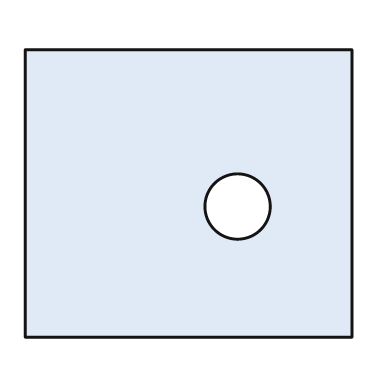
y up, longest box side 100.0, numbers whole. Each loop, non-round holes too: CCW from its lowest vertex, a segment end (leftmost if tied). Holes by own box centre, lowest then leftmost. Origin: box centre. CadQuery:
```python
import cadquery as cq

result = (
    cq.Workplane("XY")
    .moveTo(-50.0, -44.0)
    .lineTo(50.0, -44.0)
    .lineTo(50.0, 44.0)
    .lineTo(-50.0, 44.0)
    .close()
    .moveTo(15.0, -4.0)
    .circle(10.0)
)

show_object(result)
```